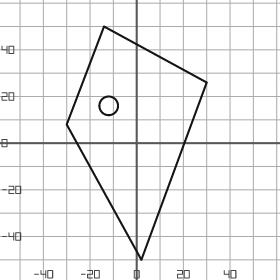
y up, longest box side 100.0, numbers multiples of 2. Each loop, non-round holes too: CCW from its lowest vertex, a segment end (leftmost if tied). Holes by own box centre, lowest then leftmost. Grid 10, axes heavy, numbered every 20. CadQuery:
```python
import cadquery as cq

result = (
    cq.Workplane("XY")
    .moveTo(2.0, -50.0)
    .lineTo(30.0, 26.0)
    .lineTo(-14.0, 50.0)
    .lineTo(-30.0, 8.0)
    .close()
    .moveTo(-12.0, 16.0)
    .circle(4.0)
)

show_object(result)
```